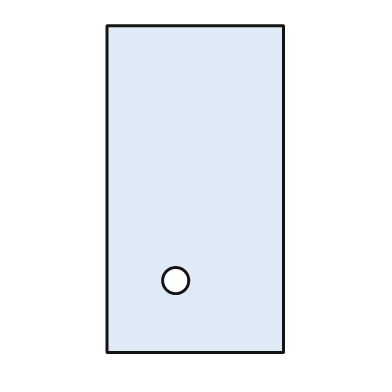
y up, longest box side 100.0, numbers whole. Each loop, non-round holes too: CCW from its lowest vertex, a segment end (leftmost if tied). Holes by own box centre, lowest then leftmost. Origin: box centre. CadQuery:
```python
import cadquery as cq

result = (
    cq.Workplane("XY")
    .moveTo(-27.0, -50.0)
    .lineTo(27.0, -50.0)
    .lineTo(27.0, 50.0)
    .lineTo(-27.0, 50.0)
    .close()
    .moveTo(-6.0, -28.0)
    .circle(4.0)
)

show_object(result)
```